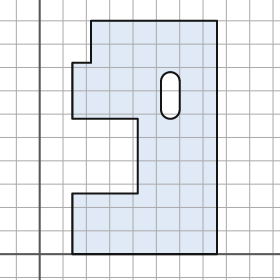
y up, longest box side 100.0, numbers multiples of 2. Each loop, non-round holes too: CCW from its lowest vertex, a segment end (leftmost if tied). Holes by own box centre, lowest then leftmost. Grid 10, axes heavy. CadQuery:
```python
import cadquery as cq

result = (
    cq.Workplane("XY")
    .moveTo(14.0, 0.0)
    .lineTo(76.0, 0.0)
    .lineTo(76.0, 100.0)
    .lineTo(22.0, 100.0)
    .lineTo(22.0, 82.0)
    .lineTo(14.0, 82.0)
    .lineTo(14.0, 58.0)
    .lineTo(42.0, 58.0)
    .lineTo(42.0, 26.0)
    .lineTo(14.0, 26.0)
    .close()
    .moveTo(52.0, 62.0)
    .threePointArc((56.0, 58.0), (60.0, 62.0))
    .lineTo(60.0, 74.0)
    .threePointArc((56.0, 78.0), (52.0, 74.0))
    .close()
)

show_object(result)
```